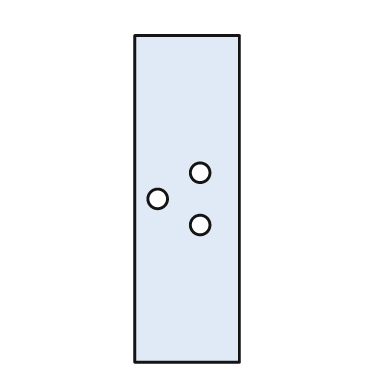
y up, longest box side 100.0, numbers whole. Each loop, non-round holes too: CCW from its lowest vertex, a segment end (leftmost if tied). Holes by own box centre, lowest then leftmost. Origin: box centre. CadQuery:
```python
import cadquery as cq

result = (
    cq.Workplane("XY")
    .moveTo(-16.0, -50.0)
    .lineTo(16.0, -50.0)
    .lineTo(16.0, 50.0)
    .lineTo(-16.0, 50.0)
    .close()
    .moveTo(4.0, -8.0)
    .circle(3.0)
    .moveTo(-9.0, 0.0)
    .circle(3.0)
    .moveTo(4.0, 8.0)
    .circle(3.0)
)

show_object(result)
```